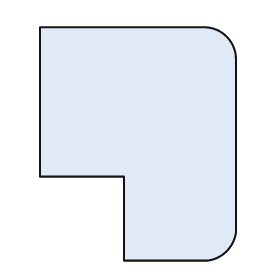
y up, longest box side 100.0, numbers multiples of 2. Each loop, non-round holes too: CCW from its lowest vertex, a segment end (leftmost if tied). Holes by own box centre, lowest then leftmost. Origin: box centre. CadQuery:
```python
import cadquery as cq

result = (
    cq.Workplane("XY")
    .moveTo(-6.0, -50.0)
    .lineTo(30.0, -50.0)
    .threePointArc((38.0, -46.0), (42.0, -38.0))
    .lineTo(42.0, 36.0)
    .threePointArc((38.0, 46.0), (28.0, 50.0))
    .lineTo(-42.0, 50.0)
    .lineTo(-42.0, -14.0)
    .lineTo(-6.0, -14.0)
    .close()
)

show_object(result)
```